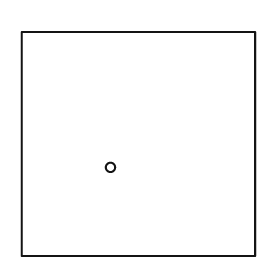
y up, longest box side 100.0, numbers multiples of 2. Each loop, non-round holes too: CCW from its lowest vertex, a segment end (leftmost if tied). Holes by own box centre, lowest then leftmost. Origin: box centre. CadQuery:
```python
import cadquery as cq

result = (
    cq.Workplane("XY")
    .moveTo(-50.0, -48.0)
    .lineTo(50.0, -48.0)
    .lineTo(50.0, 48.0)
    .lineTo(-50.0, 48.0)
    .close()
    .moveTo(-12.0, -10.0)
    .circle(2.0)
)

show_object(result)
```